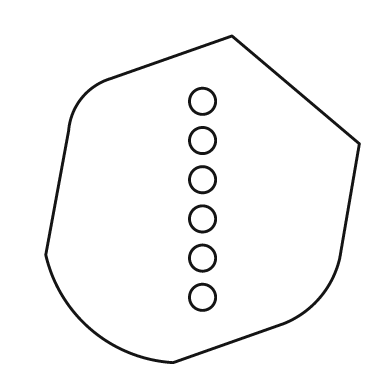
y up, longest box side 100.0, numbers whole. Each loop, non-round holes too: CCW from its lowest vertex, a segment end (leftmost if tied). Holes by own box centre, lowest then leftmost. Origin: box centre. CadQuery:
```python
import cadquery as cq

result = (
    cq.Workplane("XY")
    .moveTo(-9.0, -50.0)
    .lineTo(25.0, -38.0)
    .threePointArc((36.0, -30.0), (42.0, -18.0))
    .lineTo(48.0, 17.0)
    .lineTo(9.0, 50.0)
    .lineTo(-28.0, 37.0)
    .threePointArc((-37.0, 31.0), (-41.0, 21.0))
    .lineTo(-48.0, -17.0)
    .threePointArc((-34.0, -40.0), (-9.0, -50.0))
    .close()
    .moveTo(0.0, -30.0)
    .circle(4.0)
    .moveTo(0.0, -18.0)
    .circle(4.0)
    .moveTo(0.0, -6.0)
    .circle(4.0)
    .moveTo(0.0, 6.0)
    .circle(4.0)
    .moveTo(0.0, 18.0)
    .circle(4.0)
    .moveTo(0.0, 30.0)
    .circle(4.0)
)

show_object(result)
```